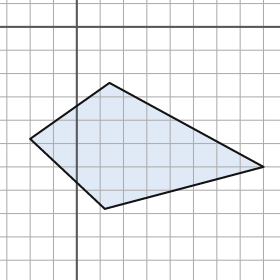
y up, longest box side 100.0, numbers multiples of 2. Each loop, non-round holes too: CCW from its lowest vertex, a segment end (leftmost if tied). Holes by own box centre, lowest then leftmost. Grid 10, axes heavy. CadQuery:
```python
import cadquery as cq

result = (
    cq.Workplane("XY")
    .moveTo(12.0, -78.0)
    .lineTo(80.0, -60.0)
    .lineTo(14.0, -24.0)
    .lineTo(-20.0, -48.0)
    .close()
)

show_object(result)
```